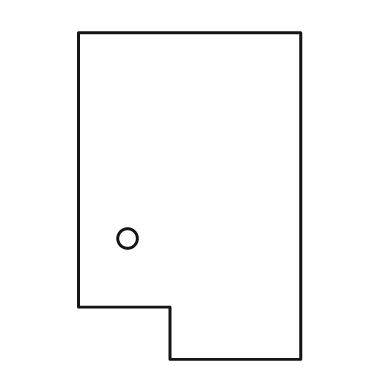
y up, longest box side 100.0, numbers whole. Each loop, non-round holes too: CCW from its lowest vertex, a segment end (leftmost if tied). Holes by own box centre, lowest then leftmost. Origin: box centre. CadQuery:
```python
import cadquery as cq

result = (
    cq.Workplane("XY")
    .moveTo(-6.0, -50.0)
    .lineTo(34.0, -50.0)
    .lineTo(34.0, 50.0)
    .lineTo(-34.0, 50.0)
    .lineTo(-34.0, -34.0)
    .lineTo(-6.0, -34.0)
    .close()
    .moveTo(-19.0, -13.0)
    .circle(3.0)
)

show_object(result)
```